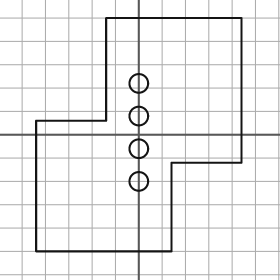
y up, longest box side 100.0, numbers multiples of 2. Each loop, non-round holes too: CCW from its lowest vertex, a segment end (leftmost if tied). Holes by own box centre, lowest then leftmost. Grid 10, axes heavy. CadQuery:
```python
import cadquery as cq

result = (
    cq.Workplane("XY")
    .moveTo(-44.0, -50.0)
    .lineTo(14.0, -50.0)
    .lineTo(14.0, -12.0)
    .lineTo(44.0, -12.0)
    .lineTo(44.0, 50.0)
    .lineTo(-14.0, 50.0)
    .lineTo(-14.0, 6.0)
    .lineTo(-44.0, 6.0)
    .close()
    .moveTo(0.0, -20.0)
    .circle(4.0)
    .moveTo(0.0, -6.0)
    .circle(4.0)
    .moveTo(0.0, 8.0)
    .circle(4.0)
    .moveTo(0.0, 22.0)
    .circle(4.0)
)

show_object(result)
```